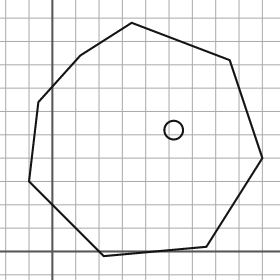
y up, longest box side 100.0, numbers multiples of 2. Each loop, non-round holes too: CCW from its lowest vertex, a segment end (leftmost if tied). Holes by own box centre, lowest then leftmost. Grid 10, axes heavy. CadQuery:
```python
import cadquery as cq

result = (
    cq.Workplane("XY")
    .moveTo(22.0, -2.0)
    .lineTo(66.0, 2.0)
    .lineTo(90.0, 40.0)
    .lineTo(76.0, 82.0)
    .lineTo(34.0, 98.0)
    .lineTo(12.0, 84.0)
    .lineTo(-6.0, 64.0)
    .lineTo(-10.0, 30.0)
    .close()
    .moveTo(52.0, 52.0)
    .circle(4.0)
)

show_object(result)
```